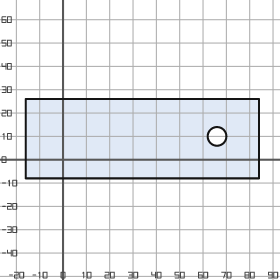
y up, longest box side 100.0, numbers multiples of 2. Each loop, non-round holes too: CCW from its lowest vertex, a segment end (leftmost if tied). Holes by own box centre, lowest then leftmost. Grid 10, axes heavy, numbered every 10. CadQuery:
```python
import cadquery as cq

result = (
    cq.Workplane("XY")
    .moveTo(-16.0, -8.0)
    .lineTo(84.0, -8.0)
    .lineTo(84.0, 26.0)
    .lineTo(-16.0, 26.0)
    .close()
    .moveTo(66.0, 10.0)
    .circle(4.0)
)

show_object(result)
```